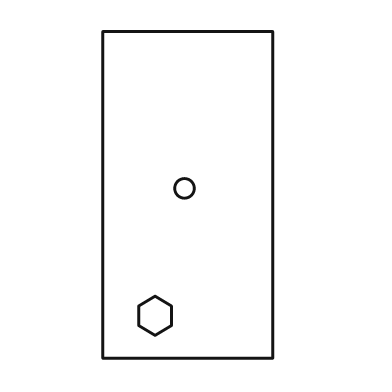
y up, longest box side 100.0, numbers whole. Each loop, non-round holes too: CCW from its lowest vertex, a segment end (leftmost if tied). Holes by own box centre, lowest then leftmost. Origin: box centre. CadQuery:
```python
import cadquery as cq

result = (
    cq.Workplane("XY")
    .moveTo(-26.0, -50.0)
    .lineTo(26.0, -50.0)
    .lineTo(26.0, 50.0)
    .lineTo(-26.0, 50.0)
    .close()
    .moveTo(-10.0, -43.0)
    .lineTo(-5.0, -40.0)
    .lineTo(-5.0, -34.0)
    .lineTo(-10.0, -31.0)
    .lineTo(-15.0, -34.0)
    .lineTo(-15.0, -40.0)
    .close()
    .moveTo(-1.0, 2.0)
    .circle(3.0)
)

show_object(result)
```